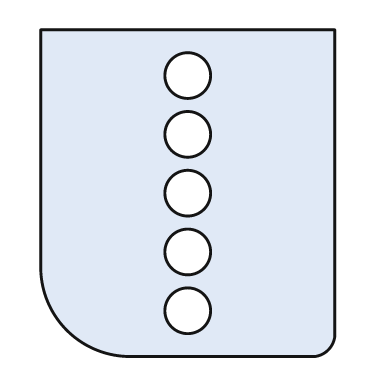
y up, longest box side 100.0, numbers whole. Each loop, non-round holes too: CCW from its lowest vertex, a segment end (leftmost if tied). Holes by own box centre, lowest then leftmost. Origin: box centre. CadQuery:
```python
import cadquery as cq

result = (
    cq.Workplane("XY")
    .moveTo(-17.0, -50.0)
    .lineTo(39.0, -50.0)
    .threePointArc((43.0, -48.0), (45.0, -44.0))
    .lineTo(45.0, 50.0)
    .lineTo(-45.0, 50.0)
    .lineTo(-45.0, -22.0)
    .threePointArc((-37.0, -42.0), (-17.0, -50.0))
    .close()
    .moveTo(0.0, -36.0)
    .circle(7.0)
    .moveTo(0.0, -18.0)
    .circle(7.0)
    .moveTo(0.0, 0.0)
    .circle(7.0)
    .moveTo(0.0, 18.0)
    .circle(7.0)
    .moveTo(0.0, 36.0)
    .circle(7.0)
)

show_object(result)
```